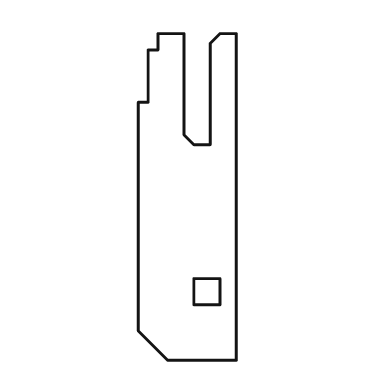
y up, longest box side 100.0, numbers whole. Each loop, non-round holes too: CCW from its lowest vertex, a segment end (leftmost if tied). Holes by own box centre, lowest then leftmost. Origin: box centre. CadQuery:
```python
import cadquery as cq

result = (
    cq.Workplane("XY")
    .moveTo(-6.0, -50.0)
    .lineTo(15.0, -50.0)
    .lineTo(15.0, 50.0)
    .lineTo(10.0, 50.0)
    .lineTo(7.0, 47.0)
    .lineTo(7.0, 16.0)
    .lineTo(2.0, 16.0)
    .lineTo(-1.0, 19.0)
    .lineTo(-1.0, 50.0)
    .lineTo(-9.0, 50.0)
    .lineTo(-9.0, 45.0)
    .lineTo(-12.0, 45.0)
    .lineTo(-12.0, 29.0)
    .lineTo(-15.0, 29.0)
    .lineTo(-15.0, -41.0)
    .close()
    .moveTo(2.0, -33.0)
    .lineTo(10.0, -33.0)
    .lineTo(10.0, -25.0)
    .lineTo(2.0, -25.0)
    .close()
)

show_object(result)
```